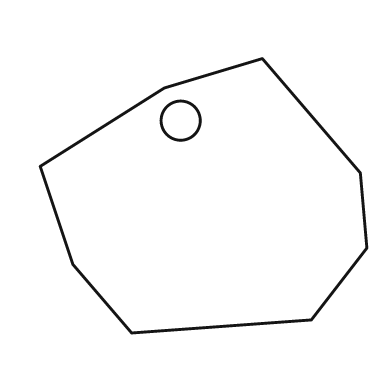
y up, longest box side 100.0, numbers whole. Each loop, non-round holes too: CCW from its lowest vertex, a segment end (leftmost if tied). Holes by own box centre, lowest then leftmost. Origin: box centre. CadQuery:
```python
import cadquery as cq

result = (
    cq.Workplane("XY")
    .moveTo(-22.0, -42.0)
    .lineTo(33.0, -38.0)
    .lineTo(50.0, -16.0)
    .lineTo(48.0, 7.0)
    .lineTo(18.0, 42.0)
    .lineTo(-12.0, 33.0)
    .lineTo(-50.0, 9.0)
    .lineTo(-40.0, -21.0)
    .close()
    .moveTo(-7.0, 23.0)
    .circle(6.0)
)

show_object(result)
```